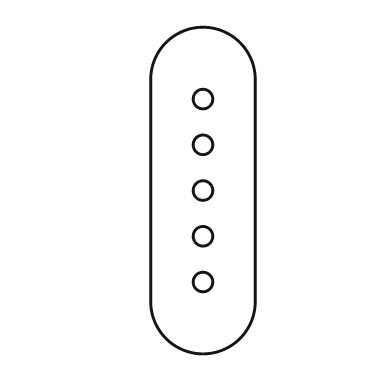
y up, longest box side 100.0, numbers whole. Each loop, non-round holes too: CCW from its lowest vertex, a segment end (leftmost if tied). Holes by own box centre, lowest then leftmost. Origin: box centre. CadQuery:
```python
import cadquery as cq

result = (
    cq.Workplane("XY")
    .moveTo(-16.0, -34.0)
    .threePointArc((0.0, -50.0), (16.0, -34.0))
    .lineTo(16.0, 34.0)
    .threePointArc((0.0, 50.0), (-16.0, 34.0))
    .close()
    .moveTo(0.0, -28.0)
    .circle(3.0)
    .moveTo(0.0, -14.0)
    .circle(3.0)
    .moveTo(0.0, 0.0)
    .circle(3.0)
    .moveTo(0.0, 14.0)
    .circle(3.0)
    .moveTo(0.0, 28.0)
    .circle(3.0)
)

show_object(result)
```